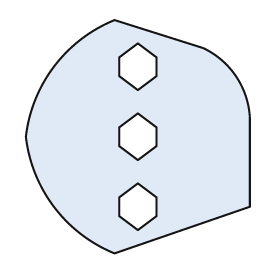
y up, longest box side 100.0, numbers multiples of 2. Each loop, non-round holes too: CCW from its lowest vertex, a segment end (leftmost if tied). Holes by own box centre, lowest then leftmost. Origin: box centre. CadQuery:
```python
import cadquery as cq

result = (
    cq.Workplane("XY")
    .moveTo(-10.0, -50.0)
    .lineTo(48.0, -30.0)
    .lineTo(48.0, 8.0)
    .threePointArc((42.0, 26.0), (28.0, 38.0))
    .lineTo(-10.0, 50.0)
    .threePointArc((-36.0, 30.0), (-48.0, 0.0))
    .threePointArc((-36.0, -30.0), (-10.0, -50.0))
    .close()
    .moveTo(0.0, -40.0)
    .lineTo(8.0, -34.0)
    .lineTo(8.0, -26.0)
    .lineTo(0.0, -20.0)
    .lineTo(-8.0, -26.0)
    .lineTo(-8.0, -34.0)
    .close()
    .moveTo(0.0, -10.0)
    .lineTo(8.0, -4.0)
    .lineTo(8.0, 4.0)
    .lineTo(0.0, 10.0)
    .lineTo(-8.0, 4.0)
    .lineTo(-8.0, -4.0)
    .close()
    .moveTo(0.0, 20.0)
    .lineTo(8.0, 26.0)
    .lineTo(8.0, 34.0)
    .lineTo(0.0, 40.0)
    .lineTo(-8.0, 34.0)
    .lineTo(-8.0, 26.0)
    .close()
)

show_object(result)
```